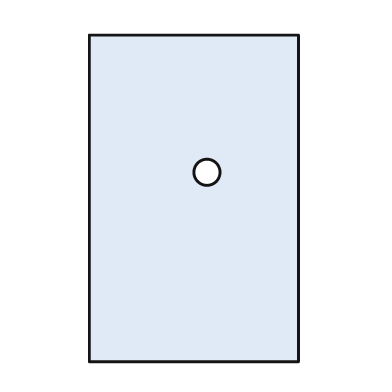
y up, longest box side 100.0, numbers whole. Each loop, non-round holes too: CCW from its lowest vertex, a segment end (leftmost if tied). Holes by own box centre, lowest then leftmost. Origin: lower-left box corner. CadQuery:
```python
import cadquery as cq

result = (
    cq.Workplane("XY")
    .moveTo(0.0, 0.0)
    .lineTo(64.0, 0.0)
    .lineTo(64.0, 100.0)
    .lineTo(0.0, 100.0)
    .close()
    .moveTo(36.0, 58.0)
    .circle(4.0)
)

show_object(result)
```